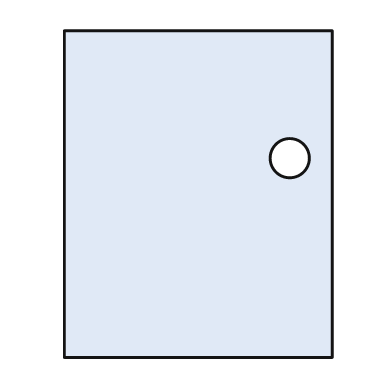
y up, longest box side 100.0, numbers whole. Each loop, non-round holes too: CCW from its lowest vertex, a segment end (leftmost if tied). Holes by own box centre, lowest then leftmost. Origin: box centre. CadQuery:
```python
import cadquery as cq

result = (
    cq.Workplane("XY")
    .moveTo(-41.0, -50.0)
    .lineTo(41.0, -50.0)
    .lineTo(41.0, 50.0)
    .lineTo(-41.0, 50.0)
    .close()
    .moveTo(28.0, 11.0)
    .circle(6.0)
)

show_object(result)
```